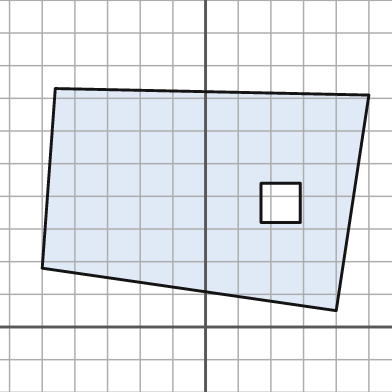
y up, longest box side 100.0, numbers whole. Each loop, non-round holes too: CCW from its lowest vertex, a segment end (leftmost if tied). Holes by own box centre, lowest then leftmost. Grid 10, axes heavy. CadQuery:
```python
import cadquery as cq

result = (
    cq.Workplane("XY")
    .moveTo(40.0, 5.0)
    .lineTo(50.0, 71.0)
    .lineTo(-46.0, 73.0)
    .lineTo(-50.0, 18.0)
    .close()
    .moveTo(17.0, 32.0)
    .lineTo(29.0, 32.0)
    .lineTo(29.0, 44.0)
    .lineTo(17.0, 44.0)
    .close()
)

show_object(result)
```